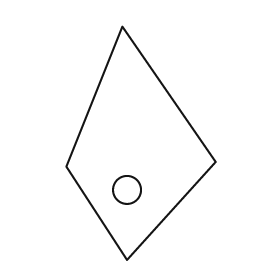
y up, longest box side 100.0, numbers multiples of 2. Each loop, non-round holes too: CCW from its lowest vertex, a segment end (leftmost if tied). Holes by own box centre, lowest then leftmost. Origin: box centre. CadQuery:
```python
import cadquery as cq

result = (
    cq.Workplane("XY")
    .moveTo(-6.0, -50.0)
    .lineTo(32.0, -8.0)
    .lineTo(-8.0, 50.0)
    .lineTo(-32.0, -10.0)
    .close()
    .moveTo(-6.0, -20.0)
    .circle(6.0)
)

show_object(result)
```